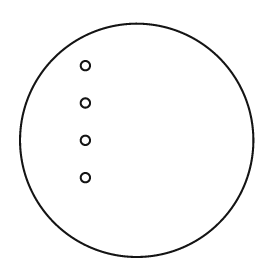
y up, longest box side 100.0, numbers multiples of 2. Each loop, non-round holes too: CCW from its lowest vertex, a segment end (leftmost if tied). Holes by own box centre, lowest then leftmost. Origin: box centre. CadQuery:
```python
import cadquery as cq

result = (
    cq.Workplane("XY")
    .moveTo(0.0, 0.0)
    .circle(50.0)
    .moveTo(-22.0, -16.0)
    .circle(2.0)
    .moveTo(-22.0, 0.0)
    .circle(2.0)
    .moveTo(-22.0, 16.0)
    .circle(2.0)
    .moveTo(-22.0, 32.0)
    .circle(2.0)
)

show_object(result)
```